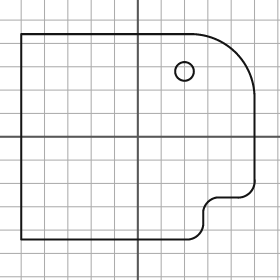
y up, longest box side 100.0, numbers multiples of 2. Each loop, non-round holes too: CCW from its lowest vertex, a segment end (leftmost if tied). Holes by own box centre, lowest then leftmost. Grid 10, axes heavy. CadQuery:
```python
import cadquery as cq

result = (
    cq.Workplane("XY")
    .moveTo(-50.0, -44.0)
    .lineTo(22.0, -44.0)
    .threePointArc((26.0, -42.0), (28.0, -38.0))
    .lineTo(28.0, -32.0)
    .threePointArc((30.0, -28.0), (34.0, -26.0))
    .lineTo(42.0, -26.0)
    .threePointArc((48.0, -24.0), (50.0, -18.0))
    .lineTo(50.0, 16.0)
    .threePointArc((42.0, 36.0), (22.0, 44.0))
    .lineTo(-50.0, 44.0)
    .close()
    .moveTo(20.0, 28.0)
    .circle(4.0)
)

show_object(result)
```